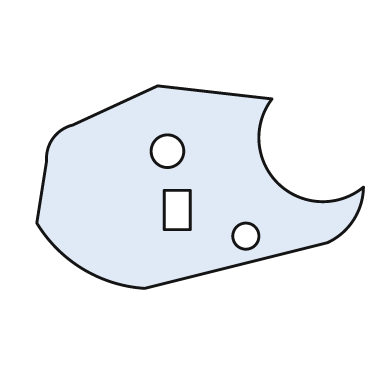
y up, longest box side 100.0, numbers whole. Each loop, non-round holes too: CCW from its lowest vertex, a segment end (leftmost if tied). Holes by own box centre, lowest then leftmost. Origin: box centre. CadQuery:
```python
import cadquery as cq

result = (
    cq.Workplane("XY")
    .moveTo(-17.0, -31.0)
    .lineTo(39.0, -17.0)
    .threePointArc((47.0, -10.0), (50.0, 0.0))
    .threePointArc((24.0, 1.0), (22.0, 27.0))
    .lineTo(-13.0, 31.0)
    .lineTo(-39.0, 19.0)
    .threePointArc((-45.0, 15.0), (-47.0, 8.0))
    .lineTo(-50.0, -11.0)
    .threePointArc((-36.0, -25.0), (-17.0, -31.0))
    .close()
    .moveTo(14.0, -15.0)
    .circle(4.0)
    .moveTo(-11.0, -13.0)
    .lineTo(-3.0, -13.0)
    .lineTo(-3.0, -1.0)
    .lineTo(-11.0, -1.0)
    .close()
    .moveTo(-10.0, 11.0)
    .circle(5.0)
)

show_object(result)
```